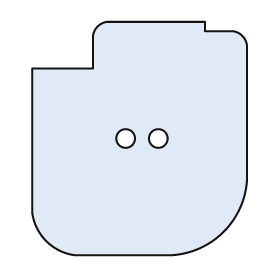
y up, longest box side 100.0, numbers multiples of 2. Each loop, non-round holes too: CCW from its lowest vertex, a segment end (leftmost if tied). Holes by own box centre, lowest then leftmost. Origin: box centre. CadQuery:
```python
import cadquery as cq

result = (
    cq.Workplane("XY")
    .moveTo(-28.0, -50.0)
    .lineTo(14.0, -50.0)
    .threePointArc((36.0, -40.0), (46.0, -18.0))
    .lineTo(46.0, 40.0)
    .threePointArc((44.0, 44.0), (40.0, 46.0))
    .lineTo(28.0, 46.0)
    .lineTo(28.0, 50.0)
    .lineTo(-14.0, 50.0)
    .threePointArc((-18.0, 48.0), (-20.0, 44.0))
    .lineTo(-20.0, 30.0)
    .lineTo(-46.0, 30.0)
    .lineTo(-46.0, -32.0)
    .threePointArc((-40.0, -44.0), (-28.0, -50.0))
    .close()
    .moveTo(-6.0, 0.0)
    .circle(4.0)
    .moveTo(8.0, 0.0)
    .circle(4.0)
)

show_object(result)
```